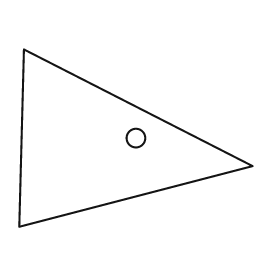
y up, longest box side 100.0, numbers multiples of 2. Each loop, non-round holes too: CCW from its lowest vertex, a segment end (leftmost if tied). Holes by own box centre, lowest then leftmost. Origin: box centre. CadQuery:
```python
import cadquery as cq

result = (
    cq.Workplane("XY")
    .moveTo(-50.0, -38.0)
    .lineTo(50.0, -12.0)
    .lineTo(-48.0, 38.0)
    .close()
    .moveTo(0.0, 0.0)
    .circle(4.0)
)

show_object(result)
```